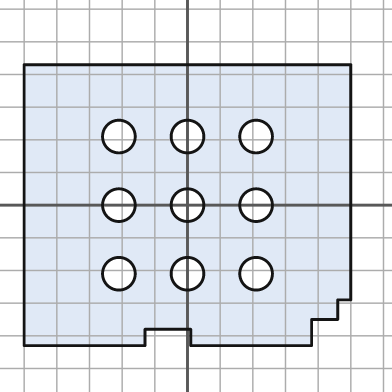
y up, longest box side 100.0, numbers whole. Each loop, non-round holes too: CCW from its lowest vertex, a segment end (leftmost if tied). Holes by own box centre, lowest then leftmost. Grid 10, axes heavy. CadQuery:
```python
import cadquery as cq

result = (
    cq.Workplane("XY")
    .moveTo(-50.0, -43.0)
    .lineTo(-13.0, -43.0)
    .lineTo(-13.0, -38.0)
    .lineTo(1.0, -38.0)
    .lineTo(1.0, -43.0)
    .lineTo(38.0, -43.0)
    .lineTo(38.0, -35.0)
    .lineTo(46.0, -35.0)
    .lineTo(46.0, -29.0)
    .lineTo(50.0, -29.0)
    .lineTo(50.0, 43.0)
    .lineTo(-50.0, 43.0)
    .close()
    .moveTo(-21.0, -21.0)
    .circle(5.0)
    .moveTo(0.0, -21.0)
    .circle(5.0)
    .moveTo(21.0, -21.0)
    .circle(5.0)
    .moveTo(-21.0, 0.0)
    .circle(5.0)
    .moveTo(0.0, 0.0)
    .circle(5.0)
    .moveTo(21.0, 0.0)
    .circle(5.0)
    .moveTo(-21.0, 21.0)
    .circle(5.0)
    .moveTo(0.0, 21.0)
    .circle(5.0)
    .moveTo(21.0, 21.0)
    .circle(5.0)
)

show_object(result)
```